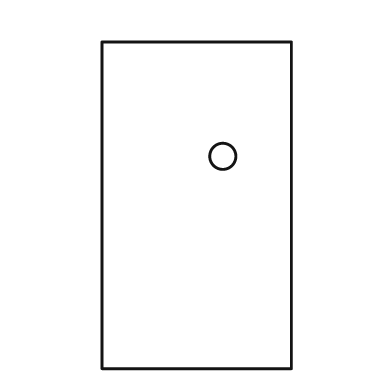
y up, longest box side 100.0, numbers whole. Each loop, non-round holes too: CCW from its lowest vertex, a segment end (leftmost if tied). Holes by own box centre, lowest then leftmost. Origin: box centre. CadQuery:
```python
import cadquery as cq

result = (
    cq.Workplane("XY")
    .moveTo(-29.0, -50.0)
    .lineTo(29.0, -50.0)
    .lineTo(29.0, 50.0)
    .lineTo(-29.0, 50.0)
    .close()
    .moveTo(8.0, 15.0)
    .circle(4.0)
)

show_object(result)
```